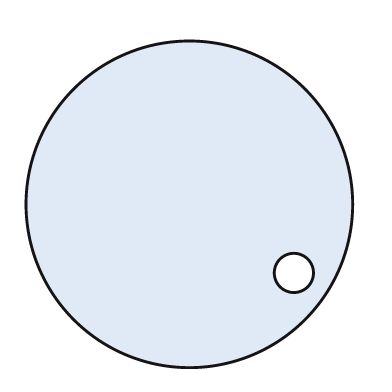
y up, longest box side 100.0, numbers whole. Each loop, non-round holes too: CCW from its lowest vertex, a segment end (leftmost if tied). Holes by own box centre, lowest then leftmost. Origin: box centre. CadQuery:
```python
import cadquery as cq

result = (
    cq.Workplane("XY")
    .moveTo(0.0, 0.0)
    .circle(50.0)
    .moveTo(32.0, -21.0)
    .circle(6.0)
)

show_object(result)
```